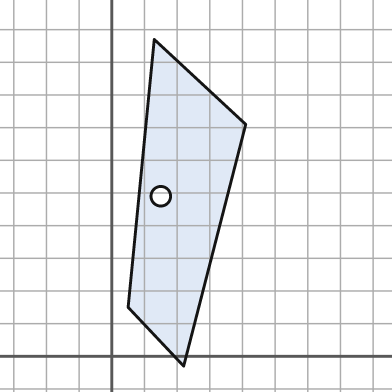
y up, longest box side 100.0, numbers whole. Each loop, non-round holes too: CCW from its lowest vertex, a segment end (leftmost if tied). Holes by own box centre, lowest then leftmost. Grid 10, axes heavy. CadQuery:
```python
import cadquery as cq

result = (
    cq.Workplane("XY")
    .moveTo(22.0, -3.0)
    .lineTo(41.0, 71.0)
    .lineTo(13.0, 97.0)
    .lineTo(5.0, 15.0)
    .close()
    .moveTo(15.0, 49.0)
    .circle(3.0)
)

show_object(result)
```